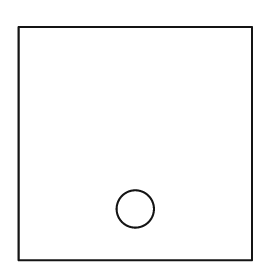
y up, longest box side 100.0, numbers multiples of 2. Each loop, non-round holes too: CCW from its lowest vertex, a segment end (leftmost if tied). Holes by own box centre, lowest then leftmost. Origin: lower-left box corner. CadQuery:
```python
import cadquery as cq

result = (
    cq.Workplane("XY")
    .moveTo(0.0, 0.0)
    .lineTo(100.0, 0.0)
    .lineTo(100.0, 100.0)
    .lineTo(0.0, 100.0)
    .close()
    .moveTo(50.0, 22.0)
    .circle(8.0)
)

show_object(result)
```